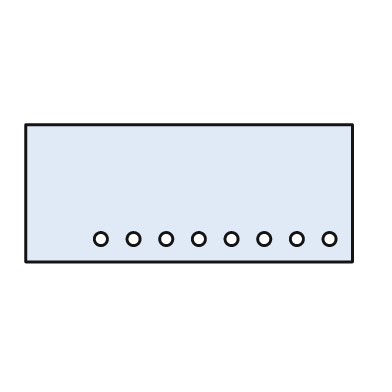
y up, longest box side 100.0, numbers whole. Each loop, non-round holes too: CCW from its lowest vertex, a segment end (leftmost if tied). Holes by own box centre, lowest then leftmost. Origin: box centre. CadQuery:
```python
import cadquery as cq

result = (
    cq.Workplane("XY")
    .moveTo(-50.0, -21.0)
    .lineTo(50.0, -21.0)
    .lineTo(50.0, 21.0)
    .lineTo(-50.0, 21.0)
    .close()
    .moveTo(-27.0, -14.0)
    .circle(2.0)
    .moveTo(-17.0, -14.0)
    .circle(2.0)
    .moveTo(-7.0, -14.0)
    .circle(2.0)
    .moveTo(3.0, -14.0)
    .circle(2.0)
    .moveTo(13.0, -14.0)
    .circle(2.0)
    .moveTo(23.0, -14.0)
    .circle(2.0)
    .moveTo(33.0, -14.0)
    .circle(2.0)
    .moveTo(43.0, -14.0)
    .circle(2.0)
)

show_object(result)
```